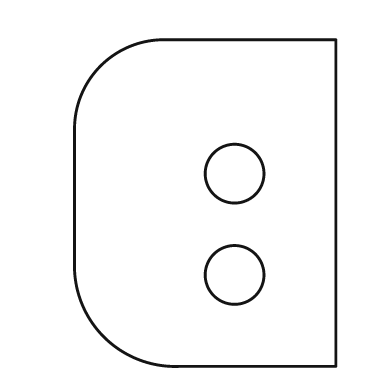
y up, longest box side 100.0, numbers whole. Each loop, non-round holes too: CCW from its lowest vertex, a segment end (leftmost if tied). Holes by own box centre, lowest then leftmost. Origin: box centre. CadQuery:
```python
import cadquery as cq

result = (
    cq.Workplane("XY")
    .moveTo(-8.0, -50.0)
    .lineTo(40.0, -50.0)
    .lineTo(40.0, 50.0)
    .lineTo(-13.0, 50.0)
    .threePointArc((-32.0, 42.0), (-40.0, 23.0))
    .lineTo(-40.0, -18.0)
    .threePointArc((-31.0, -41.0), (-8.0, -50.0))
    .close()
    .moveTo(9.0, -22.0)
    .circle(9.0)
    .moveTo(9.0, 9.0)
    .circle(9.0)
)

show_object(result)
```